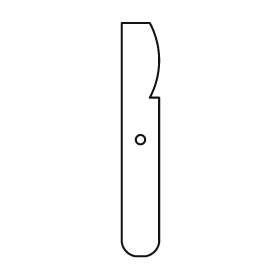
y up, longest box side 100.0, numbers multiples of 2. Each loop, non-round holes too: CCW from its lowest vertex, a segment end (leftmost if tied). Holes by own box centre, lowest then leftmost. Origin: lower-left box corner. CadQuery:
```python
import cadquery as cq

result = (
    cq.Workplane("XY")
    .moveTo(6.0, 0.0)
    .lineTo(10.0, 0.0)
    .threePointArc((14.0, 2.0), (16.0, 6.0))
    .lineTo(16.0, 68.0)
    .lineTo(12.0, 68.0)
    .threePointArc((16.0, 84.0), (12.0, 100.0))
    .lineTo(0.0, 100.0)
    .lineTo(0.0, 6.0)
    .threePointArc((2.0, 2.0), (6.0, 0.0))
    .close()
    .moveTo(8.0, 50.0)
    .circle(2.0)
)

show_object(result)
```